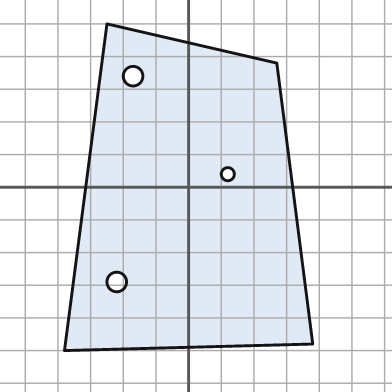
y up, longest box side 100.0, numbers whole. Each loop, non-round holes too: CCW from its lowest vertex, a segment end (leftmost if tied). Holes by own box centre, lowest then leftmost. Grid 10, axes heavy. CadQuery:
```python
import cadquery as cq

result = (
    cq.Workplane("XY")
    .moveTo(-38.0, -50.0)
    .lineTo(38.0, -48.0)
    .lineTo(27.0, 38.0)
    .lineTo(-25.0, 50.0)
    .close()
    .moveTo(-22.0, -29.0)
    .circle(3.0)
    .moveTo(12.0, 4.0)
    .circle(2.0)
    .moveTo(-17.0, 34.0)
    .circle(3.0)
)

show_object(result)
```